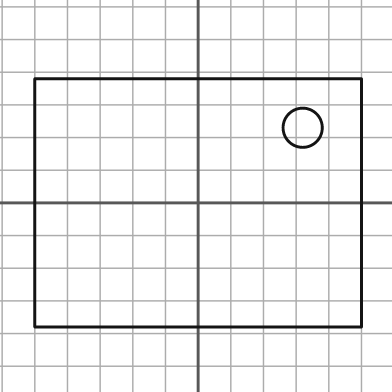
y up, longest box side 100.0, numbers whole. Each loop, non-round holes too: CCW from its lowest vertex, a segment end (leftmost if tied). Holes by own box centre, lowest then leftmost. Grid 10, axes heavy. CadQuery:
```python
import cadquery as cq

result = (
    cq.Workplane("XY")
    .moveTo(-50.0, -38.0)
    .lineTo(50.0, -38.0)
    .lineTo(50.0, 38.0)
    .lineTo(-50.0, 38.0)
    .close()
    .moveTo(32.0, 23.0)
    .circle(6.0)
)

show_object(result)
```